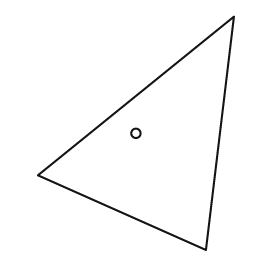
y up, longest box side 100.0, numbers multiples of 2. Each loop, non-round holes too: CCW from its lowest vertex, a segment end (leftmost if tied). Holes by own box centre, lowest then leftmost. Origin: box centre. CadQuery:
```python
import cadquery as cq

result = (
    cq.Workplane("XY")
    .moveTo(30.0, -50.0)
    .lineTo(42.0, 50.0)
    .lineTo(-42.0, -18.0)
    .close()
    .moveTo(0.0, 0.0)
    .circle(2.0)
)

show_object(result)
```